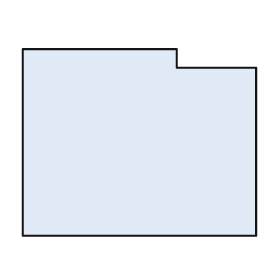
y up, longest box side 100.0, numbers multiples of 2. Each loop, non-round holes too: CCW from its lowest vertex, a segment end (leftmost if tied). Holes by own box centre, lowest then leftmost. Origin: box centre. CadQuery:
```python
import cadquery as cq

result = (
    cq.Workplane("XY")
    .moveTo(-50.0, -40.0)
    .lineTo(50.0, -40.0)
    .lineTo(50.0, 32.0)
    .lineTo(16.0, 32.0)
    .lineTo(16.0, 40.0)
    .lineTo(-50.0, 40.0)
    .close()
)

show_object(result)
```